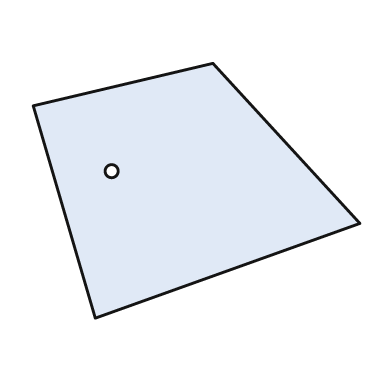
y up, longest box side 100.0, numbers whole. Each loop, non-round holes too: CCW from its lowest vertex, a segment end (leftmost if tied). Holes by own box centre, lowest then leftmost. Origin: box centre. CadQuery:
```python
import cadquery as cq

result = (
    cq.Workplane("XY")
    .moveTo(-31.0, -39.0)
    .lineTo(50.0, -10.0)
    .lineTo(5.0, 39.0)
    .lineTo(-50.0, 26.0)
    .close()
    .moveTo(-26.0, 6.0)
    .circle(2.0)
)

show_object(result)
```